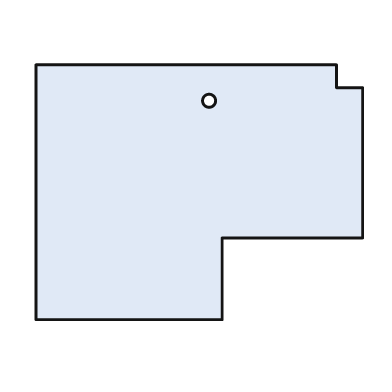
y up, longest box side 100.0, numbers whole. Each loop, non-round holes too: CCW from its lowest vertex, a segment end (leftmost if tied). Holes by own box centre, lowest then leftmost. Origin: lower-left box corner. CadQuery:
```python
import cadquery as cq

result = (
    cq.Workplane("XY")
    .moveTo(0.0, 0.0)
    .lineTo(57.0, 0.0)
    .lineTo(57.0, 25.0)
    .lineTo(100.0, 25.0)
    .lineTo(100.0, 71.0)
    .lineTo(92.0, 71.0)
    .lineTo(92.0, 78.0)
    .lineTo(0.0, 78.0)
    .close()
    .moveTo(53.0, 67.0)
    .circle(2.0)
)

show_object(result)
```